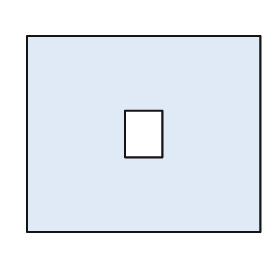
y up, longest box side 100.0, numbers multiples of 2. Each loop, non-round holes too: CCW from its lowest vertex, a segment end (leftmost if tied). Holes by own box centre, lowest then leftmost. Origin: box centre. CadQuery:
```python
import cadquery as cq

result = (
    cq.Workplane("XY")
    .moveTo(-50.0, -42.0)
    .lineTo(50.0, -42.0)
    .lineTo(50.0, 42.0)
    .lineTo(-50.0, 42.0)
    .close()
    .moveTo(-8.0, -10.0)
    .lineTo(8.0, -10.0)
    .lineTo(8.0, 10.0)
    .lineTo(-8.0, 10.0)
    .close()
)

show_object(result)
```